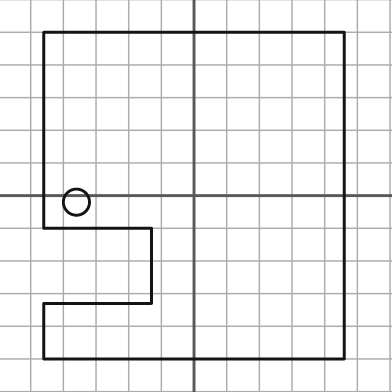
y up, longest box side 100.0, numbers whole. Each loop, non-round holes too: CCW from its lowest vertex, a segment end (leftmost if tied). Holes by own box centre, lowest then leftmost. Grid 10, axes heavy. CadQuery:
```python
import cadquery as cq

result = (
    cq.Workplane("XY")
    .moveTo(-46.0, -50.0)
    .lineTo(46.0, -50.0)
    .lineTo(46.0, 50.0)
    .lineTo(-46.0, 50.0)
    .lineTo(-46.0, -10.0)
    .lineTo(-13.0, -10.0)
    .lineTo(-13.0, -33.0)
    .lineTo(-46.0, -33.0)
    .close()
    .moveTo(-36.0, -2.0)
    .circle(4.0)
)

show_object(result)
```